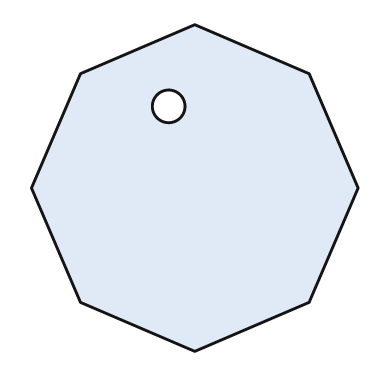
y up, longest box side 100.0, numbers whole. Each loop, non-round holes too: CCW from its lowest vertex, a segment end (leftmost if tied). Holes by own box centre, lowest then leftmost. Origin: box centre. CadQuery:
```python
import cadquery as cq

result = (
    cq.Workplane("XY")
    .moveTo(0.0, -50.0)
    .lineTo(35.0, -35.0)
    .lineTo(50.0, 0.0)
    .lineTo(35.0, 35.0)
    .lineTo(0.0, 50.0)
    .lineTo(-35.0, 35.0)
    .lineTo(-50.0, 0.0)
    .lineTo(-35.0, -35.0)
    .close()
    .moveTo(-8.0, 25.0)
    .circle(5.0)
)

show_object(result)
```